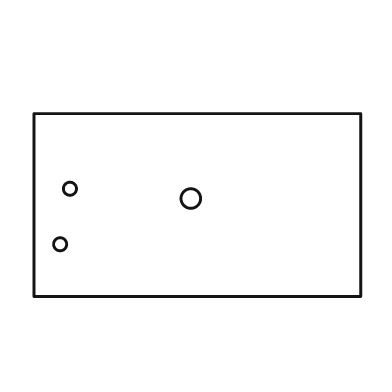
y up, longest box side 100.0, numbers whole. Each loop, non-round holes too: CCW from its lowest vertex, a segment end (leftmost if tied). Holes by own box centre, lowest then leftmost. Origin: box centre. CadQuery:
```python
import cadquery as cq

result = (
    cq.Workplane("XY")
    .moveTo(-50.0, -28.0)
    .lineTo(50.0, -28.0)
    .lineTo(50.0, 28.0)
    .lineTo(-50.0, 28.0)
    .close()
    .moveTo(-42.0, -12.0)
    .circle(2.0)
    .moveTo(-2.0, 2.0)
    .circle(3.0)
    .moveTo(-39.0, 5.0)
    .circle(2.0)
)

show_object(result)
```